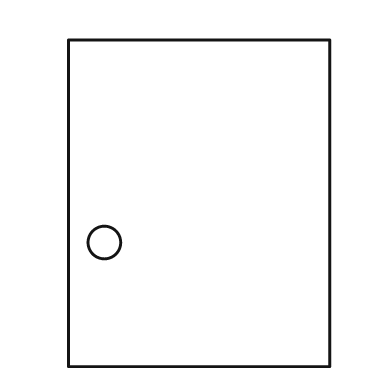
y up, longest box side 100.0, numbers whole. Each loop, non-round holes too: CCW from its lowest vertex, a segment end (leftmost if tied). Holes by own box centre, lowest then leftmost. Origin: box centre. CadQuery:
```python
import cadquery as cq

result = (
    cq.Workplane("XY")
    .moveTo(-40.0, -50.0)
    .lineTo(40.0, -50.0)
    .lineTo(40.0, 50.0)
    .lineTo(-40.0, 50.0)
    .close()
    .moveTo(-29.0, -12.0)
    .circle(5.0)
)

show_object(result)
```